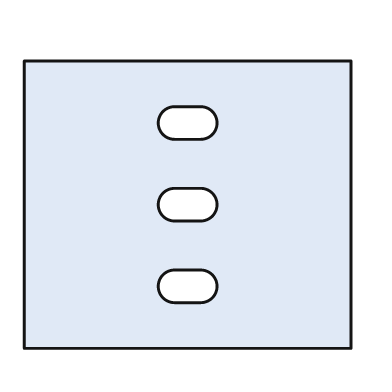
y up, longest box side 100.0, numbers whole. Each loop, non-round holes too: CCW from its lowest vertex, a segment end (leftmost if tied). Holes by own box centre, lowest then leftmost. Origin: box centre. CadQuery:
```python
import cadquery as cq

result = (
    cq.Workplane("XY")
    .moveTo(-50.0, -44.0)
    .lineTo(50.0, -44.0)
    .lineTo(50.0, 44.0)
    .lineTo(-50.0, 44.0)
    .close()
    .moveTo(-4.0, -30.0)
    .lineTo(4.0, -30.0)
    .threePointArc((9.0, -25.0), (4.0, -20.0))
    .lineTo(-4.0, -20.0)
    .threePointArc((-9.0, -25.0), (-4.0, -30.0))
    .close()
    .moveTo(-4.0, -5.0)
    .lineTo(4.0, -5.0)
    .threePointArc((9.0, 0.0), (4.0, 5.0))
    .lineTo(-4.0, 5.0)
    .threePointArc((-9.0, 0.0), (-4.0, -5.0))
    .close()
    .moveTo(-4.0, 20.0)
    .lineTo(4.0, 20.0)
    .threePointArc((9.0, 25.0), (4.0, 30.0))
    .lineTo(-4.0, 30.0)
    .threePointArc((-9.0, 25.0), (-4.0, 20.0))
    .close()
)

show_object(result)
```